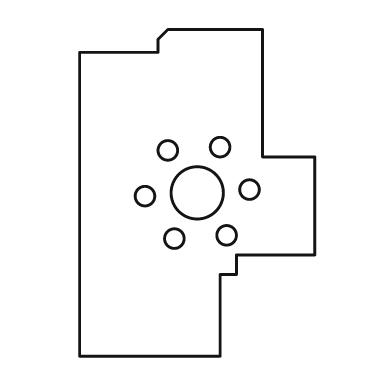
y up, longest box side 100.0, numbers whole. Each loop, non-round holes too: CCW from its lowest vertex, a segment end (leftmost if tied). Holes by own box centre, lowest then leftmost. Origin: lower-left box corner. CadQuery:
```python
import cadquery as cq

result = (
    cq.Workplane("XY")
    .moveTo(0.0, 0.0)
    .lineTo(43.0, 0.0)
    .lineTo(43.0, 25.0)
    .lineTo(48.0, 25.0)
    .lineTo(48.0, 31.0)
    .lineTo(72.0, 31.0)
    .lineTo(72.0, 61.0)
    .lineTo(56.0, 61.0)
    .lineTo(56.0, 100.0)
    .lineTo(27.0, 100.0)
    .lineTo(24.0, 97.0)
    .lineTo(24.0, 93.0)
    .lineTo(0.0, 93.0)
    .close()
    .moveTo(29.0, 36.0)
    .circle(3.0)
    .moveTo(45.0, 37.0)
    .circle(3.0)
    .moveTo(20.0, 49.0)
    .circle(3.0)
    .moveTo(36.0, 50.0)
    .circle(8.0)
    .moveTo(52.0, 51.0)
    .circle(3.0)
    .moveTo(27.0, 63.0)
    .circle(3.0)
    .moveTo(43.0, 64.0)
    .circle(3.0)
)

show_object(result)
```